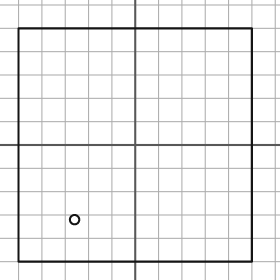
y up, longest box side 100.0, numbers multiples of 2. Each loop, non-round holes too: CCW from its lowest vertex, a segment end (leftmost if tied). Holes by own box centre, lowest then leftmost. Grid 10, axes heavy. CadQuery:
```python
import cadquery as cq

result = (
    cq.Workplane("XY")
    .moveTo(-50.0, -50.0)
    .lineTo(50.0, -50.0)
    .lineTo(50.0, 50.0)
    .lineTo(-50.0, 50.0)
    .close()
    .moveTo(-26.0, -32.0)
    .circle(2.0)
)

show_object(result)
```